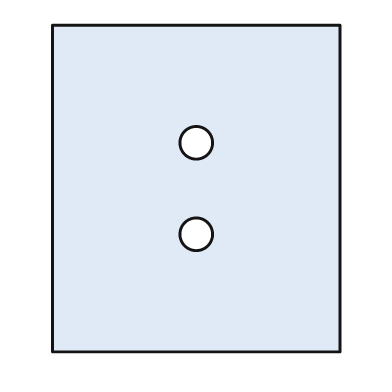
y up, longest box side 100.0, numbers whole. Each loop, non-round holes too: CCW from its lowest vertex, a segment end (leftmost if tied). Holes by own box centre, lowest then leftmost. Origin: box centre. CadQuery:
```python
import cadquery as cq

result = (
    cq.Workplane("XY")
    .moveTo(-44.0, -50.0)
    .lineTo(44.0, -50.0)
    .lineTo(44.0, 50.0)
    .lineTo(-44.0, 50.0)
    .close()
    .moveTo(0.0, -14.0)
    .circle(5.0)
    .moveTo(0.0, 14.0)
    .circle(5.0)
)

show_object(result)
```